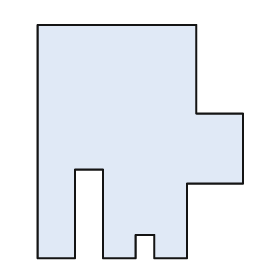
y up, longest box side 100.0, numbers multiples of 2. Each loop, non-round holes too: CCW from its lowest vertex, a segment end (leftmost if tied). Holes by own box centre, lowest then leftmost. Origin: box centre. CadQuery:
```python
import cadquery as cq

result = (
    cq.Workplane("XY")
    .moveTo(-44.0, -50.0)
    .lineTo(-28.0, -50.0)
    .lineTo(-28.0, -12.0)
    .lineTo(-16.0, -12.0)
    .lineTo(-16.0, -50.0)
    .lineTo(-2.0, -50.0)
    .lineTo(-2.0, -40.0)
    .lineTo(6.0, -40.0)
    .lineTo(6.0, -50.0)
    .lineTo(20.0, -50.0)
    .lineTo(20.0, -18.0)
    .lineTo(44.0, -18.0)
    .lineTo(44.0, 12.0)
    .lineTo(24.0, 12.0)
    .lineTo(24.0, 50.0)
    .lineTo(-44.0, 50.0)
    .close()
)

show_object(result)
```